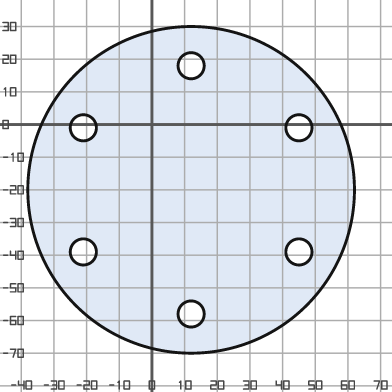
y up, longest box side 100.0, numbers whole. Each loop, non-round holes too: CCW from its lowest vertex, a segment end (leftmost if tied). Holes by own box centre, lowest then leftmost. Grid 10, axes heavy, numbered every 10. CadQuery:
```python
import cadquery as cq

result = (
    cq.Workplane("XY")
    .moveTo(12.0, -20.0)
    .circle(50.0)
    .moveTo(12.0, -58.0)
    .circle(4.0)
    .moveTo(-21.0, -39.0)
    .circle(4.0)
    .moveTo(45.0, -39.0)
    .circle(4.0)
    .moveTo(-21.0, -1.0)
    .circle(4.0)
    .moveTo(45.0, -1.0)
    .circle(4.0)
    .moveTo(12.0, 18.0)
    .circle(4.0)
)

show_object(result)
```